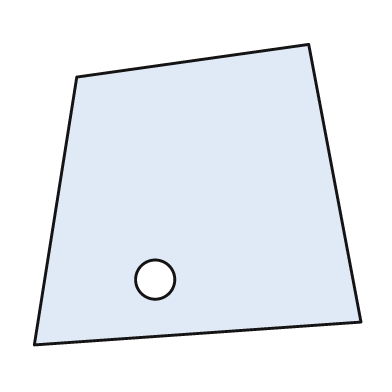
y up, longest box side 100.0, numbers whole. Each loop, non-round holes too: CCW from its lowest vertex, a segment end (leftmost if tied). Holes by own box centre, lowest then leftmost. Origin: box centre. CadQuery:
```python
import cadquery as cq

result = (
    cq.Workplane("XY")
    .moveTo(-50.0, -46.0)
    .lineTo(50.0, -39.0)
    .lineTo(34.0, 46.0)
    .lineTo(-37.0, 36.0)
    .close()
    .moveTo(-13.0, -26.0)
    .circle(6.0)
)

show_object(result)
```